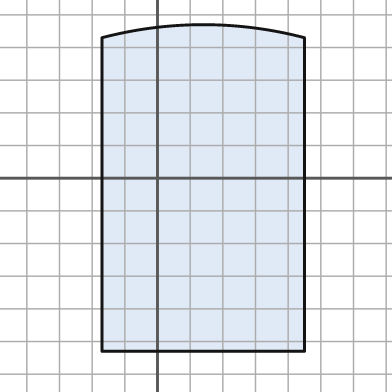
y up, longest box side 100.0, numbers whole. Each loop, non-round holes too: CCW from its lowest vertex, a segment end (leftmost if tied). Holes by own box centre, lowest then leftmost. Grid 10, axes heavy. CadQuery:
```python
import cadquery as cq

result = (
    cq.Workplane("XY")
    .moveTo(-17.0, -53.0)
    .lineTo(45.0, -53.0)
    .lineTo(45.0, 43.0)
    .threePointArc((14.0, 47.0), (-17.0, 43.0))
    .close()
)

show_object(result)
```